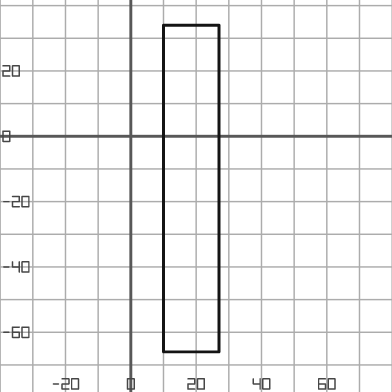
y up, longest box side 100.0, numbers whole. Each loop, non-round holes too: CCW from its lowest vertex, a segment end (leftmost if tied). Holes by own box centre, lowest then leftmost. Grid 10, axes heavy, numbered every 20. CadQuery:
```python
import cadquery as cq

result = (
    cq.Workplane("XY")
    .moveTo(10.0, -66.0)
    .lineTo(27.0, -66.0)
    .lineTo(27.0, 34.0)
    .lineTo(10.0, 34.0)
    .close()
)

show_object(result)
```